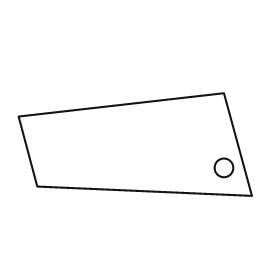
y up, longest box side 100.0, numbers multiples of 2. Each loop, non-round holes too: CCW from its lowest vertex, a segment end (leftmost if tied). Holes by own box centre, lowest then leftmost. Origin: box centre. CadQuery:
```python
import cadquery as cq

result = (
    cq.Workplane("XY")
    .moveTo(50.0, -22.0)
    .lineTo(38.0, 22.0)
    .lineTo(-50.0, 12.0)
    .lineTo(-42.0, -18.0)
    .close()
    .moveTo(38.0, -10.0)
    .circle(4.0)
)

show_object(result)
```